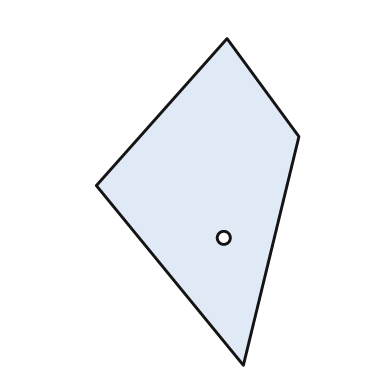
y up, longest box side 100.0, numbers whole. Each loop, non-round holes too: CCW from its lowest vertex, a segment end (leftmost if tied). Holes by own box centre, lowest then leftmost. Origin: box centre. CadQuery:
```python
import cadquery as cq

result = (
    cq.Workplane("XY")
    .moveTo(14.0, -50.0)
    .lineTo(31.0, 20.0)
    .lineTo(9.0, 50.0)
    .lineTo(-31.0, 5.0)
    .close()
    .moveTo(8.0, -11.0)
    .circle(2.0)
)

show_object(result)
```